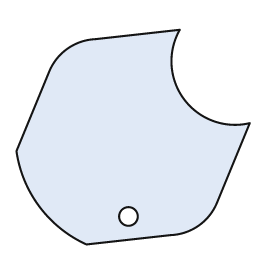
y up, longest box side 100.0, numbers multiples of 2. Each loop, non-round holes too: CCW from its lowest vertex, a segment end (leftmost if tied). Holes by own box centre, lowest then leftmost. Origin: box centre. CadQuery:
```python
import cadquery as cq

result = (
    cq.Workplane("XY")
    .moveTo(-20.0, -46.0)
    .lineTo(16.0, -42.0)
    .threePointArc((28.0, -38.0), (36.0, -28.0))
    .lineTo(50.0, 6.0)
    .threePointArc((22.0, 16.0), (20.0, 46.0))
    .lineTo(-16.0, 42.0)
    .threePointArc((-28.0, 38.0), (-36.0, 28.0))
    .lineTo(-50.0, -6.0)
    .threePointArc((-40.0, -30.0), (-20.0, -46.0))
    .close()
    .moveTo(-2.0, -34.0)
    .circle(4.0)
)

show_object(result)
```